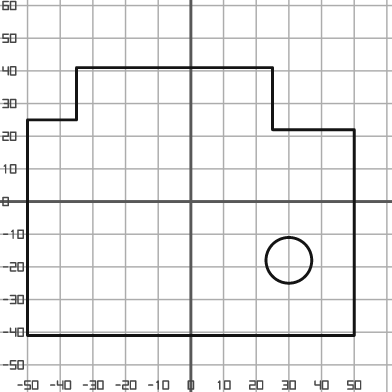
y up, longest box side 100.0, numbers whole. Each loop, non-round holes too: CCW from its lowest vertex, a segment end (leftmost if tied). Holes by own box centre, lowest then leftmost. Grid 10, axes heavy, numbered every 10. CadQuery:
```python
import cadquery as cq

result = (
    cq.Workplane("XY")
    .moveTo(-50.0, -41.0)
    .lineTo(50.0, -41.0)
    .lineTo(50.0, 22.0)
    .lineTo(25.0, 22.0)
    .lineTo(25.0, 41.0)
    .lineTo(-35.0, 41.0)
    .lineTo(-35.0, 25.0)
    .lineTo(-50.0, 25.0)
    .close()
    .moveTo(30.0, -18.0)
    .circle(7.0)
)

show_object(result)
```